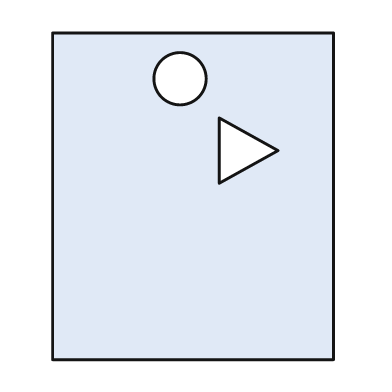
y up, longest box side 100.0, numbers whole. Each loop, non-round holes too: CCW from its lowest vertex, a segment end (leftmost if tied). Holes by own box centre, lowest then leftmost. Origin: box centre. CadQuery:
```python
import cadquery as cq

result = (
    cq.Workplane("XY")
    .moveTo(-43.0, -50.0)
    .lineTo(43.0, -50.0)
    .lineTo(43.0, 50.0)
    .lineTo(-43.0, 50.0)
    .close()
    .moveTo(8.0, 4.0)
    .lineTo(26.0, 14.0)
    .lineTo(8.0, 24.0)
    .close()
    .moveTo(-4.0, 36.0)
    .circle(8.0)
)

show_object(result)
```